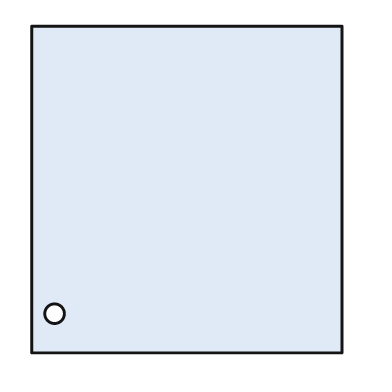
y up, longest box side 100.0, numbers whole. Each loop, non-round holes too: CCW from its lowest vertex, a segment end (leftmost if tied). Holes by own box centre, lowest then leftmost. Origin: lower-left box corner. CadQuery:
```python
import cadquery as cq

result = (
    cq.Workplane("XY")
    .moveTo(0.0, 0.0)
    .lineTo(95.0, 0.0)
    .lineTo(95.0, 100.0)
    .lineTo(0.0, 100.0)
    .close()
    .moveTo(7.0, 12.0)
    .circle(3.0)
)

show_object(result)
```